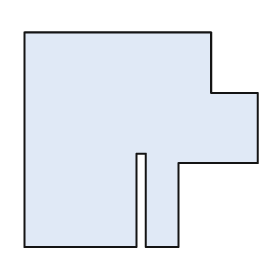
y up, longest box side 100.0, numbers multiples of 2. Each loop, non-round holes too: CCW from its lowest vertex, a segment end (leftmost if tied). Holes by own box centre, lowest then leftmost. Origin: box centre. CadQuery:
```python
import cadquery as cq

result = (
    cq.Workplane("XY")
    .moveTo(-50.0, -46.0)
    .lineTo(-2.0, -46.0)
    .lineTo(-2.0, -6.0)
    .lineTo(2.0, -6.0)
    .lineTo(2.0, -46.0)
    .lineTo(16.0, -46.0)
    .lineTo(16.0, -10.0)
    .lineTo(50.0, -10.0)
    .lineTo(50.0, 20.0)
    .lineTo(30.0, 20.0)
    .lineTo(30.0, 46.0)
    .lineTo(-50.0, 46.0)
    .close()
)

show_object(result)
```